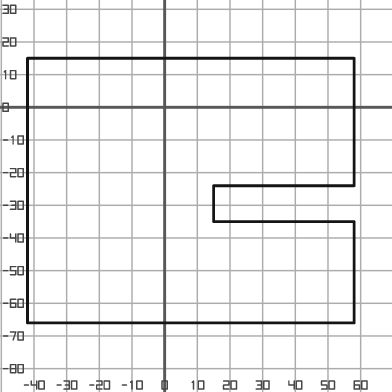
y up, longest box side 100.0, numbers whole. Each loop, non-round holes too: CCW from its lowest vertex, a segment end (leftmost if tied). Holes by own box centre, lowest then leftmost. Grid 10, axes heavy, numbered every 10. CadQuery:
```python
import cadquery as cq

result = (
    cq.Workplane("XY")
    .moveTo(-42.0, -66.0)
    .lineTo(58.0, -66.0)
    .lineTo(58.0, -35.0)
    .lineTo(15.0, -35.0)
    .lineTo(15.0, -24.0)
    .lineTo(58.0, -24.0)
    .lineTo(58.0, 15.0)
    .lineTo(-42.0, 15.0)
    .close()
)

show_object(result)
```